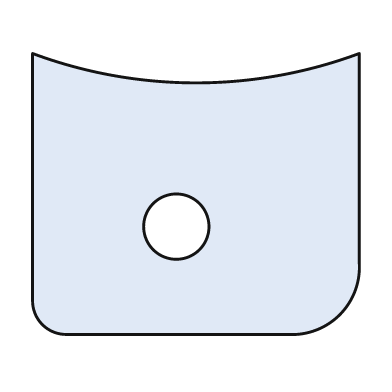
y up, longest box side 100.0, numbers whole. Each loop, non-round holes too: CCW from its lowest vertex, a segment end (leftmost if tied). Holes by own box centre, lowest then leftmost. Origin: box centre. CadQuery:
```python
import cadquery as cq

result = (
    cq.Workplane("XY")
    .moveTo(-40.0, -43.0)
    .lineTo(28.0, -43.0)
    .threePointArc((44.0, -37.0), (50.0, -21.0))
    .lineTo(50.0, 43.0)
    .threePointArc((0.0, 34.0), (-50.0, 43.0))
    .lineTo(-50.0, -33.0)
    .threePointArc((-47.0, -40.0), (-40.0, -43.0))
    .close()
    .moveTo(-6.0, -10.0)
    .circle(10.0)
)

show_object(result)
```